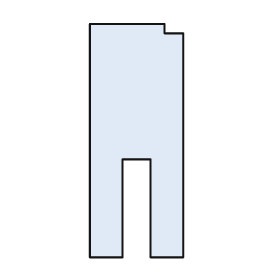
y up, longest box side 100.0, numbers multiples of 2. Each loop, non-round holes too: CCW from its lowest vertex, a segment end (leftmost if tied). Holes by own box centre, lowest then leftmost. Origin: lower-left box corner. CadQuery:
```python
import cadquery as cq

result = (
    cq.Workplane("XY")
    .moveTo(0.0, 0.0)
    .lineTo(14.0, 0.0)
    .lineTo(14.0, 42.0)
    .lineTo(26.0, 42.0)
    .lineTo(26.0, 0.0)
    .lineTo(40.0, 0.0)
    .lineTo(40.0, 96.0)
    .lineTo(32.0, 96.0)
    .lineTo(32.0, 100.0)
    .lineTo(0.0, 100.0)
    .close()
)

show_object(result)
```